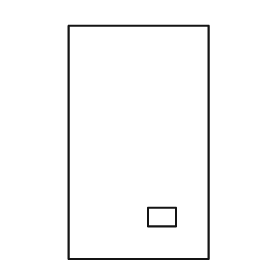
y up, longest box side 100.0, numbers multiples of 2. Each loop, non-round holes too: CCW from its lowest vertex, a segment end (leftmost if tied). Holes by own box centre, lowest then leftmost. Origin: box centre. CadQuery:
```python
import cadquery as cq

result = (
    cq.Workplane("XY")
    .moveTo(-30.0, -50.0)
    .lineTo(30.0, -50.0)
    .lineTo(30.0, 50.0)
    .lineTo(-30.0, 50.0)
    .close()
    .moveTo(4.0, -36.0)
    .lineTo(16.0, -36.0)
    .lineTo(16.0, -28.0)
    .lineTo(4.0, -28.0)
    .close()
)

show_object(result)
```